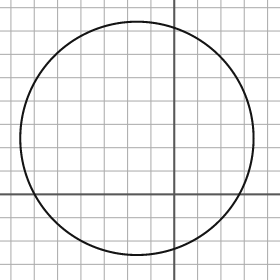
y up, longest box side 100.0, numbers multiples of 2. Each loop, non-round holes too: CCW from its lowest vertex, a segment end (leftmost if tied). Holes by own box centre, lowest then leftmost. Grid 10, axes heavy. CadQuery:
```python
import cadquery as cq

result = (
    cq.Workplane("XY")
    .moveTo(-16.0, 24.0)
    .circle(50.0)
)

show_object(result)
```